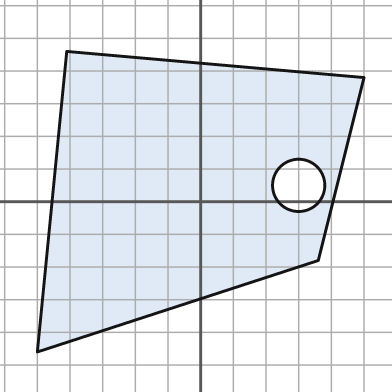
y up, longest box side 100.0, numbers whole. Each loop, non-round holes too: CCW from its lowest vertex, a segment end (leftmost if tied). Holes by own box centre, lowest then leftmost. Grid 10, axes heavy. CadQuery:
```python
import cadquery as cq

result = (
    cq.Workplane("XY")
    .moveTo(-50.0, -46.0)
    .lineTo(36.0, -18.0)
    .lineTo(50.0, 38.0)
    .lineTo(-41.0, 46.0)
    .close()
    .moveTo(30.0, 5.0)
    .circle(8.0)
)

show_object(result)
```